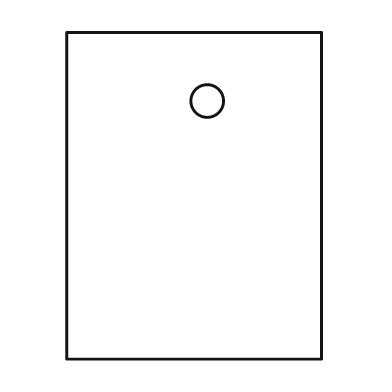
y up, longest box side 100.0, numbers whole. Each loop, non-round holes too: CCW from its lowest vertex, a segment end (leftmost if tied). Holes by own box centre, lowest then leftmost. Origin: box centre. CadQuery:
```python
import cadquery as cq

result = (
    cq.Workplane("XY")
    .moveTo(-39.0, -50.0)
    .lineTo(39.0, -50.0)
    .lineTo(39.0, 50.0)
    .lineTo(-39.0, 50.0)
    .close()
    .moveTo(4.0, 29.0)
    .circle(5.0)
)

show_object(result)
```